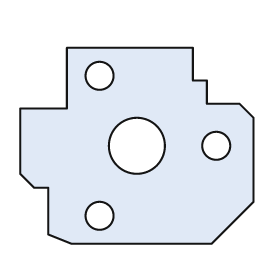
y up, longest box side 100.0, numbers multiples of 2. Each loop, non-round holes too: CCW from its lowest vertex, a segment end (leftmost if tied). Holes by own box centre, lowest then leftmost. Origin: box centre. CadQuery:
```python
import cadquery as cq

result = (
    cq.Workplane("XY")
    .moveTo(-28.0, -42.0)
    .lineTo(32.0, -42.0)
    .lineTo(50.0, -24.0)
    .lineTo(50.0, 12.0)
    .lineTo(44.0, 18.0)
    .lineTo(30.0, 18.0)
    .lineTo(30.0, 28.0)
    .lineTo(24.0, 28.0)
    .lineTo(24.0, 42.0)
    .lineTo(-30.0, 42.0)
    .lineTo(-30.0, 16.0)
    .lineTo(-50.0, 16.0)
    .lineTo(-50.0, -12.0)
    .lineTo(-44.0, -18.0)
    .lineTo(-38.0, -18.0)
    .lineTo(-38.0, -38.0)
    .close()
    .moveTo(-16.0, -30.0)
    .circle(6.0)
    .moveTo(0.0, 0.0)
    .circle(12.0)
    .moveTo(34.0, 0.0)
    .circle(6.0)
    .moveTo(-16.0, 30.0)
    .circle(6.0)
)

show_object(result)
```